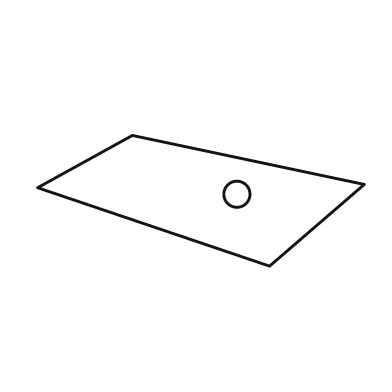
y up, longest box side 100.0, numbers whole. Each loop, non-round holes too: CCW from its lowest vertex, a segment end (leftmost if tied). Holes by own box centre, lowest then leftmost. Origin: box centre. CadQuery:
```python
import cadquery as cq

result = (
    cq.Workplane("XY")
    .moveTo(21.0, -20.0)
    .lineTo(50.0, 5.0)
    .lineTo(-21.0, 20.0)
    .lineTo(-50.0, 4.0)
    .close()
    .moveTo(11.0, 2.0)
    .circle(4.0)
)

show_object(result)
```